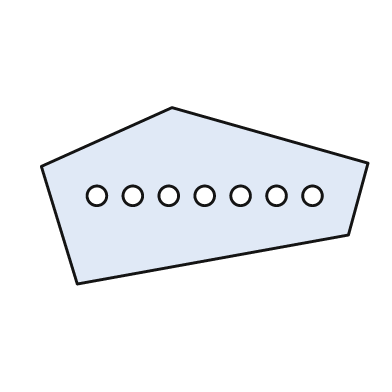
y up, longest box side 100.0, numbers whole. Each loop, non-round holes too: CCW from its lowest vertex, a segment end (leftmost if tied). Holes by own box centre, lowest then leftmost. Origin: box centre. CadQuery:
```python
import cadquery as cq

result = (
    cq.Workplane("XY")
    .moveTo(-39.0, -27.0)
    .lineTo(44.0, -12.0)
    .lineTo(50.0, 10.0)
    .lineTo(-10.0, 27.0)
    .lineTo(-50.0, 9.0)
    .close()
    .moveTo(-33.0, 0.0)
    .circle(3.0)
    .moveTo(-22.0, 0.0)
    .circle(3.0)
    .moveTo(-11.0, 0.0)
    .circle(3.0)
    .moveTo(0.0, 0.0)
    .circle(3.0)
    .moveTo(11.0, 0.0)
    .circle(3.0)
    .moveTo(22.0, 0.0)
    .circle(3.0)
    .moveTo(33.0, 0.0)
    .circle(3.0)
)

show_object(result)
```